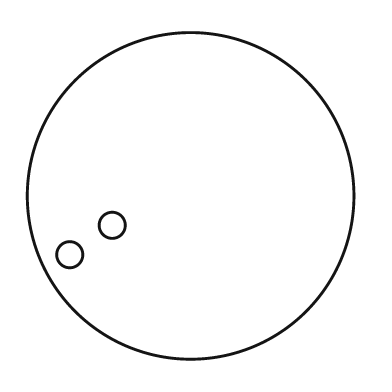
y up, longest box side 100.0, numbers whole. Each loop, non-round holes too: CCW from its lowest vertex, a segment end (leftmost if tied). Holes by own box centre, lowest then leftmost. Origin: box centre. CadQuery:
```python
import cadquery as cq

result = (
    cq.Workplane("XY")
    .moveTo(0.0, 0.0)
    .circle(50.0)
    .moveTo(-37.0, -18.0)
    .circle(4.0)
    .moveTo(-24.0, -9.0)
    .circle(4.0)
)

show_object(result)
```